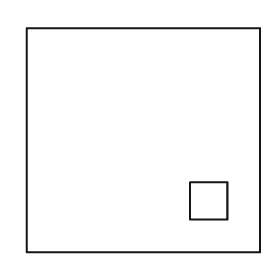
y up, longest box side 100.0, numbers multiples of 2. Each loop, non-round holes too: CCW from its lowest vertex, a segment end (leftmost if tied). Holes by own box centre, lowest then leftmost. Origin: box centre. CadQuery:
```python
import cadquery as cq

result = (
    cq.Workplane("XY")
    .moveTo(-50.0, -48.0)
    .lineTo(50.0, -48.0)
    .lineTo(50.0, 48.0)
    .lineTo(-50.0, 48.0)
    .close()
    .moveTo(20.0, -34.0)
    .lineTo(36.0, -34.0)
    .lineTo(36.0, -18.0)
    .lineTo(20.0, -18.0)
    .close()
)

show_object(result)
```